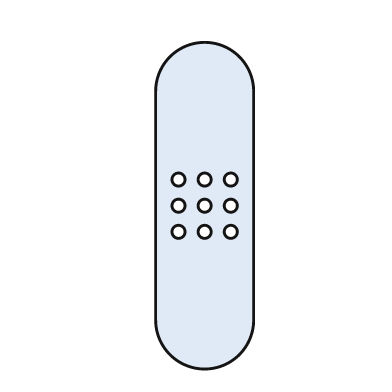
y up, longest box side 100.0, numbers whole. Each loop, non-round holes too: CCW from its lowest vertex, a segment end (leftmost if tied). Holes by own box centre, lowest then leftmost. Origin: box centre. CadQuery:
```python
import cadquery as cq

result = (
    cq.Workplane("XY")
    .moveTo(-15.0, -35.0)
    .threePointArc((0.0, -50.0), (15.0, -35.0))
    .lineTo(15.0, 35.0)
    .threePointArc((0.0, 50.0), (-15.0, 35.0))
    .close()
    .moveTo(-8.0, -8.0)
    .circle(2.0)
    .moveTo(0.0, -8.0)
    .circle(2.0)
    .moveTo(8.0, -8.0)
    .circle(2.0)
    .moveTo(-8.0, 0.0)
    .circle(2.0)
    .moveTo(0.0, 0.0)
    .circle(2.0)
    .moveTo(8.0, 0.0)
    .circle(2.0)
    .moveTo(-8.0, 8.0)
    .circle(2.0)
    .moveTo(0.0, 8.0)
    .circle(2.0)
    .moveTo(8.0, 8.0)
    .circle(2.0)
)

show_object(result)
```